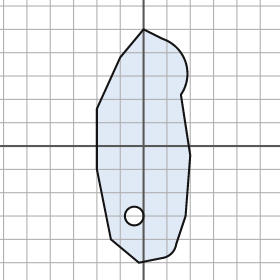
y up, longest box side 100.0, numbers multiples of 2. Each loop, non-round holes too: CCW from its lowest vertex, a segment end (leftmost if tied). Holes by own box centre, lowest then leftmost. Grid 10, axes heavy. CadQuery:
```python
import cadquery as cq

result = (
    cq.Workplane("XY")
    .moveTo(-2.0, -50.0)
    .lineTo(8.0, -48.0)
    .threePointArc((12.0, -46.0), (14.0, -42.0))
    .lineTo(18.0, -30.0)
    .lineTo(20.0, -4.0)
    .lineTo(16.0, 22.0)
    .threePointArc((18.0, 36.0), (8.0, 46.0))
    .lineTo(0.0, 50.0)
    .lineTo(-10.0, 38.0)
    .lineTo(-20.0, 16.0)
    .lineTo(-20.0, -10.0)
    .lineTo(-14.0, -40.0)
    .close()
    .moveTo(-4.0, -30.0)
    .circle(4.0)
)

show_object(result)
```